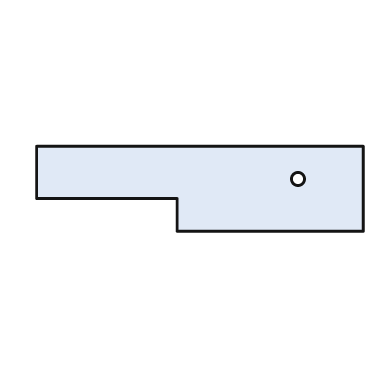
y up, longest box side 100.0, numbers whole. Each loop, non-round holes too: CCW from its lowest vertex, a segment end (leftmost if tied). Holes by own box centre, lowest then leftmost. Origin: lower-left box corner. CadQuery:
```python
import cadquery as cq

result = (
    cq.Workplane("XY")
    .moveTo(43.0, 0.0)
    .lineTo(100.0, 0.0)
    .lineTo(100.0, 26.0)
    .lineTo(0.0, 26.0)
    .lineTo(0.0, 10.0)
    .lineTo(43.0, 10.0)
    .close()
    .moveTo(80.0, 16.0)
    .circle(2.0)
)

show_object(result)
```